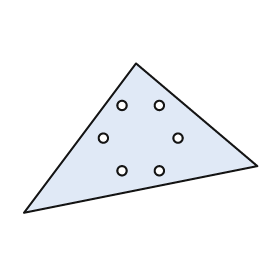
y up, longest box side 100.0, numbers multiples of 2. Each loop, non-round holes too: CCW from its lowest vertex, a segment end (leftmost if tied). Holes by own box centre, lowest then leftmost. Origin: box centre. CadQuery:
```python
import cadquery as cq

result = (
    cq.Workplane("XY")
    .moveTo(-50.0, -32.0)
    .lineTo(50.0, -12.0)
    .lineTo(-2.0, 32.0)
    .close()
    .moveTo(-8.0, -14.0)
    .circle(2.0)
    .moveTo(8.0, -14.0)
    .circle(2.0)
    .moveTo(-16.0, 0.0)
    .circle(2.0)
    .moveTo(16.0, 0.0)
    .circle(2.0)
    .moveTo(-8.0, 14.0)
    .circle(2.0)
    .moveTo(8.0, 14.0)
    .circle(2.0)
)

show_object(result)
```